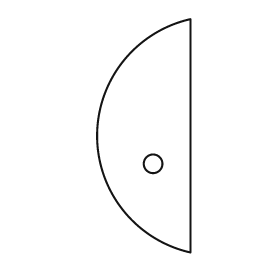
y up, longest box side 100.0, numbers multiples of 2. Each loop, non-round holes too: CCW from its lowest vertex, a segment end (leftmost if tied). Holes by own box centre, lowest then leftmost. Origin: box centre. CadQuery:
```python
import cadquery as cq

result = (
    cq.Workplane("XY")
    .moveTo(20.0, -50.0)
    .lineTo(20.0, 50.0)
    .threePointArc((-20.0, 0.0), (20.0, -50.0))
    .close()
    .moveTo(4.0, -12.0)
    .circle(4.0)
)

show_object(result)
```